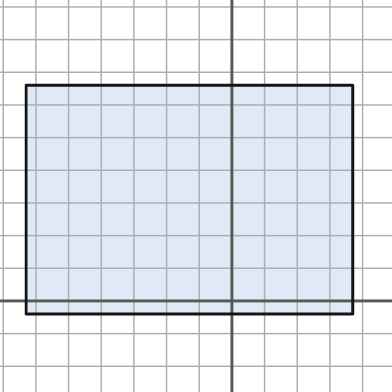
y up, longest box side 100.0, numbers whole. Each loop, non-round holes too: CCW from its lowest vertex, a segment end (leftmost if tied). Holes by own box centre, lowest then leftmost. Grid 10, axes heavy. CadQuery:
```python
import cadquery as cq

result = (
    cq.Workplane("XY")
    .moveTo(-63.0, -4.0)
    .lineTo(37.0, -4.0)
    .lineTo(37.0, 66.0)
    .lineTo(-63.0, 66.0)
    .close()
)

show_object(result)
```